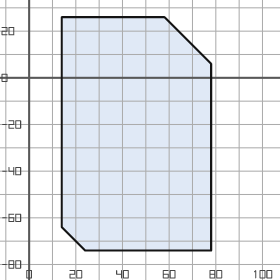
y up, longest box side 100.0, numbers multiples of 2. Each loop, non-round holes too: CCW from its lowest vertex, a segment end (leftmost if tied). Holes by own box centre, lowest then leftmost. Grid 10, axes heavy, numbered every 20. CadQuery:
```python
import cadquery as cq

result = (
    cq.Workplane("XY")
    .moveTo(24.0, -74.0)
    .lineTo(78.0, -74.0)
    .lineTo(78.0, 6.0)
    .lineTo(58.0, 26.0)
    .lineTo(14.0, 26.0)
    .lineTo(14.0, -64.0)
    .close()
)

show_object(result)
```